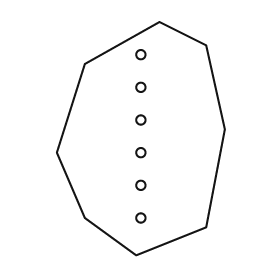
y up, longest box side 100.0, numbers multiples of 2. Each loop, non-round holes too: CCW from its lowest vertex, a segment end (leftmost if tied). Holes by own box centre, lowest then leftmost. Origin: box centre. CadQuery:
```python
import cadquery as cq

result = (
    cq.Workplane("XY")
    .moveTo(-2.0, -50.0)
    .lineTo(28.0, -38.0)
    .lineTo(36.0, 4.0)
    .lineTo(28.0, 40.0)
    .lineTo(8.0, 50.0)
    .lineTo(-24.0, 32.0)
    .lineTo(-36.0, -6.0)
    .lineTo(-24.0, -34.0)
    .close()
    .moveTo(0.0, -34.0)
    .circle(2.0)
    .moveTo(0.0, -20.0)
    .circle(2.0)
    .moveTo(0.0, -6.0)
    .circle(2.0)
    .moveTo(0.0, 8.0)
    .circle(2.0)
    .moveTo(0.0, 22.0)
    .circle(2.0)
    .moveTo(0.0, 36.0)
    .circle(2.0)
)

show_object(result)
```